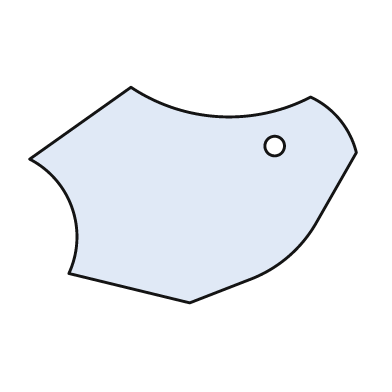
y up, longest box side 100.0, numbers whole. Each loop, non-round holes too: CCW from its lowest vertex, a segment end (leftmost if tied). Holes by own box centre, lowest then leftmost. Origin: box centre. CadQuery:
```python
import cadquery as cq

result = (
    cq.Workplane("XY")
    .moveTo(-1.0, -33.0)
    .lineTo(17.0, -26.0)
    .threePointArc((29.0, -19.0), (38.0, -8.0))
    .lineTo(50.0, 13.0)
    .threePointArc((45.0, 23.0), (36.0, 30.0))
    .threePointArc((8.0, 24.0), (-19.0, 33.0))
    .lineTo(-50.0, 11.0)
    .threePointArc((-37.0, -4.0), (-38.0, -24.0))
    .close()
    .moveTo(25.0, 15.0)
    .circle(3.0)
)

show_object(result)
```